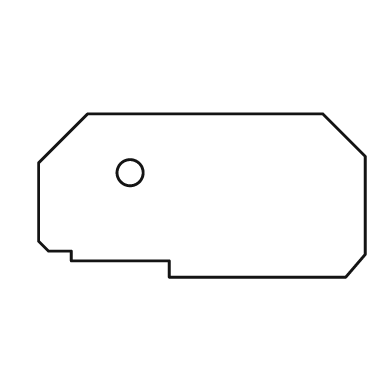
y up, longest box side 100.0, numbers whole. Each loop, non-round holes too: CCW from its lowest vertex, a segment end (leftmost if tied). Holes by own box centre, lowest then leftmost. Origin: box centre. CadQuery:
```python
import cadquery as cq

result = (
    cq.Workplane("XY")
    .moveTo(-10.0, -25.0)
    .lineTo(44.0, -25.0)
    .lineTo(50.0, -18.0)
    .lineTo(50.0, 12.0)
    .lineTo(37.0, 25.0)
    .lineTo(-35.0, 25.0)
    .lineTo(-50.0, 10.0)
    .lineTo(-50.0, -14.0)
    .lineTo(-47.0, -17.0)
    .lineTo(-40.0, -17.0)
    .lineTo(-40.0, -20.0)
    .lineTo(-10.0, -20.0)
    .close()
    .moveTo(-22.0, 7.0)
    .circle(4.0)
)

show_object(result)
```